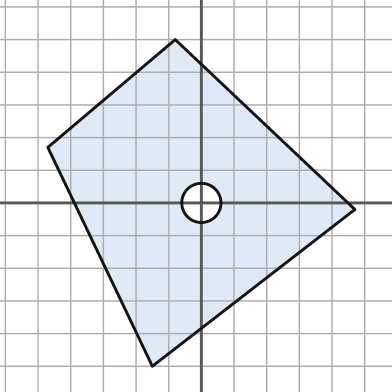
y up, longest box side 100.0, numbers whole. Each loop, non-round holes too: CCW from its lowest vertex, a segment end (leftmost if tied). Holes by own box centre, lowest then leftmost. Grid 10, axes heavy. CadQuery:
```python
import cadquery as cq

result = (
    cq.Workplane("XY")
    .moveTo(-15.0, -50.0)
    .lineTo(47.0, -2.0)
    .lineTo(-8.0, 50.0)
    .lineTo(-47.0, 17.0)
    .close()
    .moveTo(0.0, 0.0)
    .circle(6.0)
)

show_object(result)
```